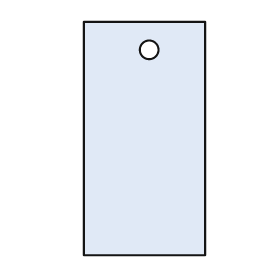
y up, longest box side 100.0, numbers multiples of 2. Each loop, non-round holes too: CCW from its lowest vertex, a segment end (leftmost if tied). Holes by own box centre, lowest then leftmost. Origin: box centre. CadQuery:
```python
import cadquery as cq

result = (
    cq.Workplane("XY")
    .moveTo(-26.0, -50.0)
    .lineTo(26.0, -50.0)
    .lineTo(26.0, 50.0)
    .lineTo(-26.0, 50.0)
    .close()
    .moveTo(2.0, 38.0)
    .circle(4.0)
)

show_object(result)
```